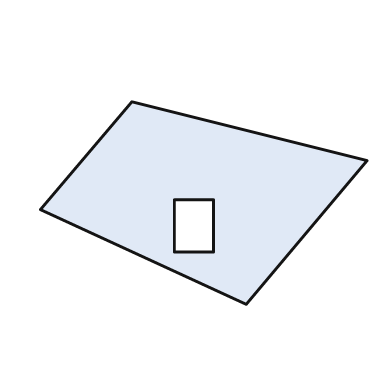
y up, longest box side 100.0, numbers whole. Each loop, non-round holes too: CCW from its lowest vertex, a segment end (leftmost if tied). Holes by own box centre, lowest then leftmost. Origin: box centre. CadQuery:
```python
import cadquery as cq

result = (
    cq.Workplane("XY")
    .moveTo(13.0, -31.0)
    .lineTo(50.0, 13.0)
    .lineTo(-22.0, 31.0)
    .lineTo(-50.0, -2.0)
    .close()
    .moveTo(-9.0, -15.0)
    .lineTo(3.0, -15.0)
    .lineTo(3.0, 1.0)
    .lineTo(-9.0, 1.0)
    .close()
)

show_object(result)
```